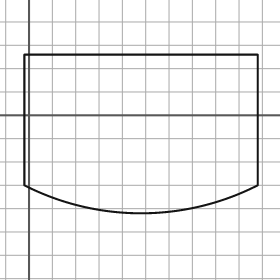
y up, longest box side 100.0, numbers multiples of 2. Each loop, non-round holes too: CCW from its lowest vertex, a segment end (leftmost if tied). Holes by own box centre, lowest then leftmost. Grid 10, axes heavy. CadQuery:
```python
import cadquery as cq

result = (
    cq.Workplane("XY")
    .moveTo(-2.0, -30.0)
    .threePointArc((48.0, -42.0), (98.0, -30.0))
    .lineTo(98.0, 26.0)
    .lineTo(-2.0, 26.0)
    .close()
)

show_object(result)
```